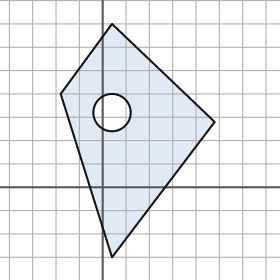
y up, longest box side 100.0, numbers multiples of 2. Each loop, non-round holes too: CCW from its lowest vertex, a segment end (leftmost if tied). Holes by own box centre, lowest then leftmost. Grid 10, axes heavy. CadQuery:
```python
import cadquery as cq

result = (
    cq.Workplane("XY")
    .moveTo(4.0, -30.0)
    .lineTo(48.0, 28.0)
    .lineTo(4.0, 70.0)
    .lineTo(-18.0, 40.0)
    .close()
    .moveTo(4.0, 32.0)
    .circle(8.0)
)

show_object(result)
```